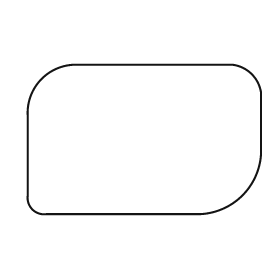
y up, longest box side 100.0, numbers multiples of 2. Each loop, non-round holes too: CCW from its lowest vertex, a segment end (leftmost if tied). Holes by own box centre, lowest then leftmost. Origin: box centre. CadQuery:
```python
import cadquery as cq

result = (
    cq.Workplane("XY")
    .moveTo(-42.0, -32.0)
    .lineTo(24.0, -32.0)
    .threePointArc((42.0, -24.0), (50.0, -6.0))
    .lineTo(50.0, 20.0)
    .threePointArc((46.0, 28.0), (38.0, 32.0))
    .lineTo(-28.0, 32.0)
    .threePointArc((-44.0, 26.0), (-50.0, 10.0))
    .lineTo(-50.0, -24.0)
    .threePointArc((-48.0, -30.0), (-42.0, -32.0))
    .close()
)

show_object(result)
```